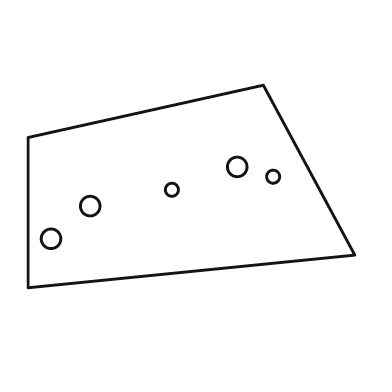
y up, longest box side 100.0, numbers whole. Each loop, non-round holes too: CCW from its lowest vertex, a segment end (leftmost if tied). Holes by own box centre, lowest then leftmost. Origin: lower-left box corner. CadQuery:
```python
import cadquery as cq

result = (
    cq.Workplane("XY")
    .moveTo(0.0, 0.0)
    .lineTo(100.0, 10.0)
    .lineTo(72.0, 62.0)
    .lineTo(0.0, 46.0)
    .close()
    .moveTo(7.0, 15.0)
    .circle(3.0)
    .moveTo(19.0, 25.0)
    .circle(3.0)
    .moveTo(44.0, 30.0)
    .circle(2.0)
    .moveTo(75.0, 34.0)
    .circle(2.0)
    .moveTo(64.0, 37.0)
    .circle(3.0)
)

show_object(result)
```